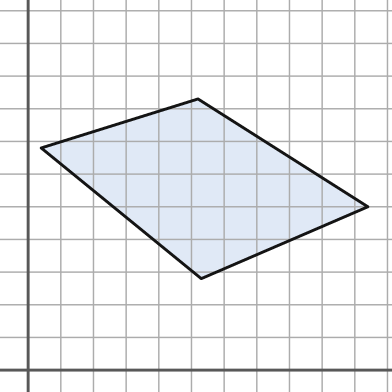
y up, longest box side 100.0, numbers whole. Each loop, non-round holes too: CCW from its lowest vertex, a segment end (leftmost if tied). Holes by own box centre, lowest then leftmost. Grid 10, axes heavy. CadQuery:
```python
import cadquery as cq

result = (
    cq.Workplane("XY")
    .moveTo(53.0, 28.0)
    .lineTo(104.0, 50.0)
    .lineTo(52.0, 83.0)
    .lineTo(4.0, 68.0)
    .close()
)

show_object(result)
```